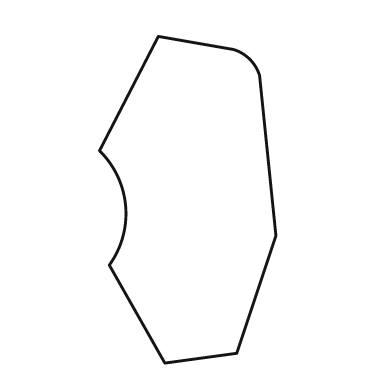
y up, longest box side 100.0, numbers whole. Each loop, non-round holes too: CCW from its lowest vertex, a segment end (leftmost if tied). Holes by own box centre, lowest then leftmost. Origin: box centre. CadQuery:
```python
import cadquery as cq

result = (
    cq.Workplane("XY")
    .moveTo(-7.0, -50.0)
    .lineTo(15.0, -47.0)
    .lineTo(27.0, -11.0)
    .lineTo(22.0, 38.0)
    .threePointArc((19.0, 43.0), (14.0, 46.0))
    .lineTo(-9.0, 50.0)
    .lineTo(-27.0, 15.0)
    .threePointArc((-19.0, -2.0), (-24.0, -20.0))
    .close()
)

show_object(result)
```